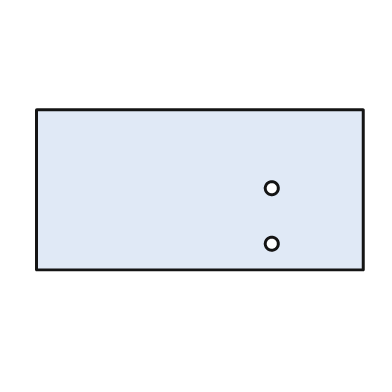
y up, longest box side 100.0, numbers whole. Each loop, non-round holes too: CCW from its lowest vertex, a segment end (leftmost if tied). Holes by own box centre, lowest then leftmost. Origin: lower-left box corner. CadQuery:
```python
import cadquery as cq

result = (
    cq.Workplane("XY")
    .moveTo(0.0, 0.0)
    .lineTo(100.0, 0.0)
    .lineTo(100.0, 49.0)
    .lineTo(0.0, 49.0)
    .close()
    .moveTo(72.0, 8.0)
    .circle(2.0)
    .moveTo(72.0, 25.0)
    .circle(2.0)
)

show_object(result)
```